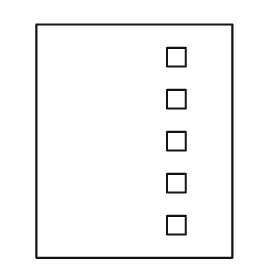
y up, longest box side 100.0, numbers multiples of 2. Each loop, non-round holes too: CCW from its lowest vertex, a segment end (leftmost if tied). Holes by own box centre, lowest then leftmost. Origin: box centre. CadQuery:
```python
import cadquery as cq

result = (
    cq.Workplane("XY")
    .moveTo(-42.0, -50.0)
    .lineTo(42.0, -50.0)
    .lineTo(42.0, 50.0)
    .lineTo(-42.0, 50.0)
    .close()
    .moveTo(14.0, -40.0)
    .lineTo(22.0, -40.0)
    .lineTo(22.0, -32.0)
    .lineTo(14.0, -32.0)
    .close()
    .moveTo(14.0, -22.0)
    .lineTo(22.0, -22.0)
    .lineTo(22.0, -14.0)
    .lineTo(14.0, -14.0)
    .close()
    .moveTo(14.0, -4.0)
    .lineTo(22.0, -4.0)
    .lineTo(22.0, 4.0)
    .lineTo(14.0, 4.0)
    .close()
    .moveTo(14.0, 14.0)
    .lineTo(22.0, 14.0)
    .lineTo(22.0, 22.0)
    .lineTo(14.0, 22.0)
    .close()
    .moveTo(14.0, 32.0)
    .lineTo(22.0, 32.0)
    .lineTo(22.0, 40.0)
    .lineTo(14.0, 40.0)
    .close()
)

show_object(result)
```